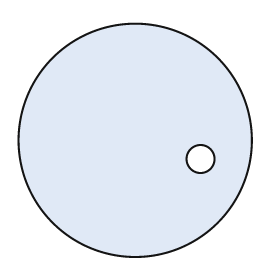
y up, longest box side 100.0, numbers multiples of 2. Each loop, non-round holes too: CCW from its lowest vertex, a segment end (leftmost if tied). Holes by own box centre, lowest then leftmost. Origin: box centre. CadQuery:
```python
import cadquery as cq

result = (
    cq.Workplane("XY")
    .moveTo(0.0, 0.0)
    .circle(50.0)
    .moveTo(28.0, -8.0)
    .circle(6.0)
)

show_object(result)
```